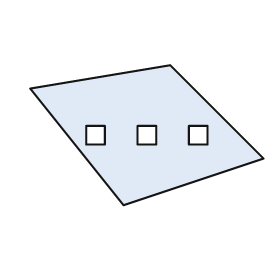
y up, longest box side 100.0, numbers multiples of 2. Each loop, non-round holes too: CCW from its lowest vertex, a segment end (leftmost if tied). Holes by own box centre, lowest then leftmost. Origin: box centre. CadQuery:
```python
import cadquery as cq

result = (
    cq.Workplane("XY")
    .moveTo(-10.0, -30.0)
    .lineTo(50.0, -10.0)
    .lineTo(10.0, 30.0)
    .lineTo(-50.0, 20.0)
    .close()
    .moveTo(-26.0, -4.0)
    .lineTo(-18.0, -4.0)
    .lineTo(-18.0, 4.0)
    .lineTo(-26.0, 4.0)
    .close()
    .moveTo(-4.0, -4.0)
    .lineTo(4.0, -4.0)
    .lineTo(4.0, 4.0)
    .lineTo(-4.0, 4.0)
    .close()
    .moveTo(18.0, -4.0)
    .lineTo(26.0, -4.0)
    .lineTo(26.0, 4.0)
    .lineTo(18.0, 4.0)
    .close()
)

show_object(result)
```